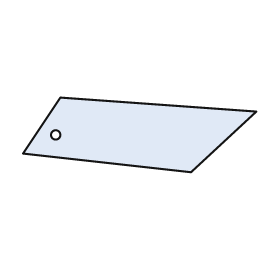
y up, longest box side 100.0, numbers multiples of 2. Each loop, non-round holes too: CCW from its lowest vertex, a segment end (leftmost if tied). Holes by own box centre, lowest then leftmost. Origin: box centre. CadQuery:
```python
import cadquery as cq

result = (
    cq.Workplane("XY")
    .moveTo(22.0, -16.0)
    .lineTo(50.0, 10.0)
    .lineTo(-34.0, 16.0)
    .lineTo(-50.0, -8.0)
    .close()
    .moveTo(-36.0, 0.0)
    .circle(2.0)
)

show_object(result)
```